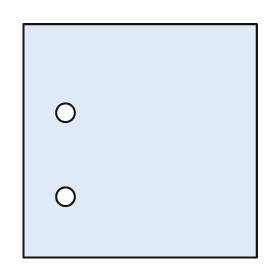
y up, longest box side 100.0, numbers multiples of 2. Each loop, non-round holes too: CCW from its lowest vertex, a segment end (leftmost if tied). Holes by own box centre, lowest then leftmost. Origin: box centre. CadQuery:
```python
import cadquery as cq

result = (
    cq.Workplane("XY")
    .moveTo(-50.0, -50.0)
    .lineTo(50.0, -50.0)
    .lineTo(50.0, 50.0)
    .lineTo(-50.0, 50.0)
    .close()
    .moveTo(-32.0, -24.0)
    .circle(4.0)
    .moveTo(-32.0, 12.0)
    .circle(4.0)
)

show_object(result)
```